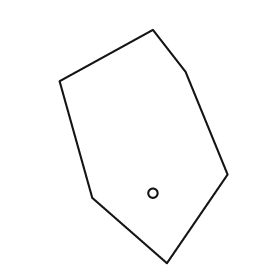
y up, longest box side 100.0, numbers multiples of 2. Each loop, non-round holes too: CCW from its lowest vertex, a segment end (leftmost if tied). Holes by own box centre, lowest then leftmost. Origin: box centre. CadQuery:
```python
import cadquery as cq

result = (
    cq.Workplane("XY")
    .moveTo(10.0, -50.0)
    .lineTo(36.0, -12.0)
    .lineTo(18.0, 32.0)
    .lineTo(4.0, 50.0)
    .lineTo(-36.0, 28.0)
    .lineTo(-22.0, -22.0)
    .close()
    .moveTo(4.0, -20.0)
    .circle(2.0)
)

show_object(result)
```